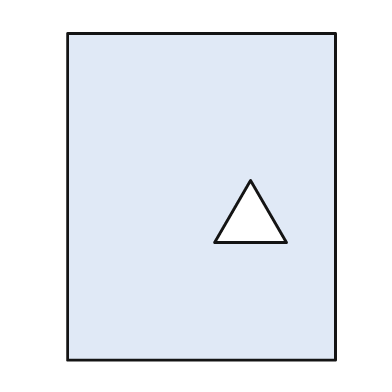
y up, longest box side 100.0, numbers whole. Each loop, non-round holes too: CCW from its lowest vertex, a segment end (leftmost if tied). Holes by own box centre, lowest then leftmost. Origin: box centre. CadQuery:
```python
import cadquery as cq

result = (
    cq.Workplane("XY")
    .moveTo(-41.0, -50.0)
    .lineTo(41.0, -50.0)
    .lineTo(41.0, 50.0)
    .lineTo(-41.0, 50.0)
    .close()
    .moveTo(4.0, -14.0)
    .lineTo(26.0, -14.0)
    .lineTo(15.0, 5.0)
    .close()
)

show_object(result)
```